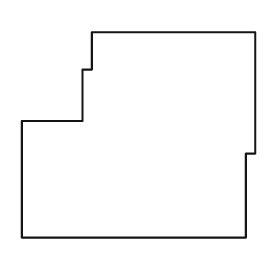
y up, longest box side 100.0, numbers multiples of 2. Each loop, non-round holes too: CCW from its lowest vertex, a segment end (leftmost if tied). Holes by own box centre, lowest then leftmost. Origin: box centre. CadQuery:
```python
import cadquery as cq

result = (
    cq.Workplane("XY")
    .moveTo(-50.0, -44.0)
    .lineTo(46.0, -44.0)
    .lineTo(46.0, -8.0)
    .lineTo(50.0, -8.0)
    .lineTo(50.0, 44.0)
    .lineTo(-20.0, 44.0)
    .lineTo(-20.0, 28.0)
    .lineTo(-24.0, 28.0)
    .lineTo(-24.0, 6.0)
    .lineTo(-50.0, 6.0)
    .close()
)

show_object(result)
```